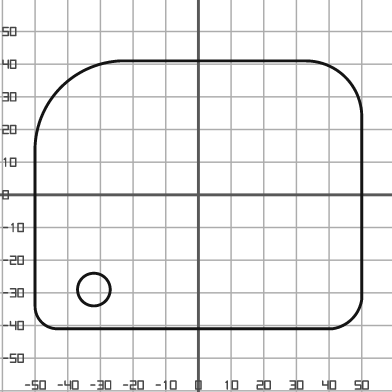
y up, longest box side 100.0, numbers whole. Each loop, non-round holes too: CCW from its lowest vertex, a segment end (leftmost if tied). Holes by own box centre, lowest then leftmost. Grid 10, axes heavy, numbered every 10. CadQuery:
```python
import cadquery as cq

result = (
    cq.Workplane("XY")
    .moveTo(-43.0, -41.0)
    .lineTo(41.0, -41.0)
    .threePointArc((47.0, -38.0), (50.0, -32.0))
    .lineTo(50.0, 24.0)
    .threePointArc((45.0, 36.0), (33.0, 41.0))
    .lineTo(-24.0, 41.0)
    .threePointArc((-42.0, 33.0), (-50.0, 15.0))
    .lineTo(-50.0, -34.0)
    .threePointArc((-48.0, -39.0), (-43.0, -41.0))
    .close()
    .moveTo(-32.0, -29.0)
    .circle(5.0)
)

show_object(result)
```